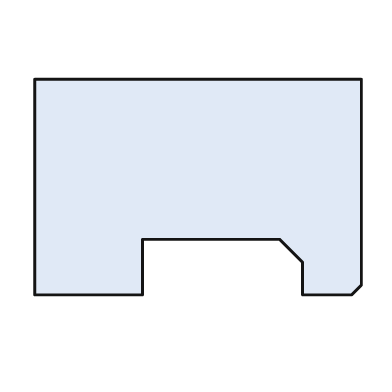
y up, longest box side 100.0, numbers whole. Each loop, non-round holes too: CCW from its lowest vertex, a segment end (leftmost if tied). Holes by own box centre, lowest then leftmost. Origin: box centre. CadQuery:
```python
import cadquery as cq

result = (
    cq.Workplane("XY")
    .moveTo(-50.0, -33.0)
    .lineTo(-17.0, -33.0)
    .lineTo(-17.0, -16.0)
    .lineTo(25.0, -16.0)
    .lineTo(32.0, -23.0)
    .lineTo(32.0, -33.0)
    .lineTo(47.0, -33.0)
    .lineTo(50.0, -30.0)
    .lineTo(50.0, 33.0)
    .lineTo(-50.0, 33.0)
    .close()
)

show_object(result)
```